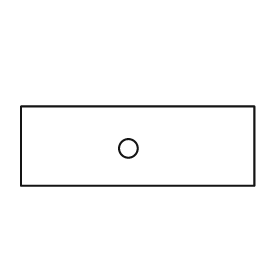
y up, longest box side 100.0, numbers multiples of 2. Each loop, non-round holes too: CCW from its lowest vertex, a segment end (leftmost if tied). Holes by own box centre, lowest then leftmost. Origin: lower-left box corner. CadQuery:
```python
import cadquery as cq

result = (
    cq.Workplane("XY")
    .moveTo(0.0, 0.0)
    .lineTo(100.0, 0.0)
    .lineTo(100.0, 34.0)
    .lineTo(0.0, 34.0)
    .close()
    .moveTo(46.0, 16.0)
    .circle(4.0)
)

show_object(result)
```